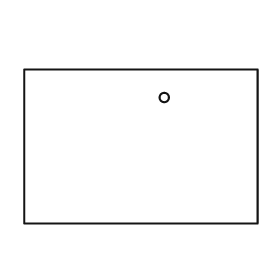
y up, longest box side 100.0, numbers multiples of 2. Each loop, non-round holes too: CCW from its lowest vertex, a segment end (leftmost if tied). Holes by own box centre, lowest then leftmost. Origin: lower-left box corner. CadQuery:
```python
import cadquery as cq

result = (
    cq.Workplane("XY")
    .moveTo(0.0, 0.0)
    .lineTo(100.0, 0.0)
    .lineTo(100.0, 66.0)
    .lineTo(0.0, 66.0)
    .close()
    .moveTo(60.0, 54.0)
    .circle(2.0)
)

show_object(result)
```